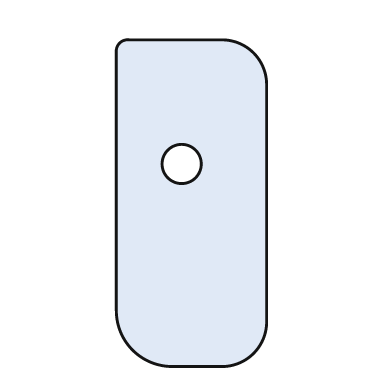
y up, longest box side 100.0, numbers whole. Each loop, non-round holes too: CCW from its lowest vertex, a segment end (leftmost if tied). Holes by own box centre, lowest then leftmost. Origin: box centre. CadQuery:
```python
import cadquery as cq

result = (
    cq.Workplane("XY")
    .moveTo(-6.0, -50.0)
    .lineTo(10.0, -50.0)
    .threePointArc((19.0, -46.0), (23.0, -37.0))
    .lineTo(23.0, 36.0)
    .threePointArc((19.0, 46.0), (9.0, 50.0))
    .lineTo(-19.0, 50.0)
    .threePointArc((-22.0, 49.0), (-23.0, 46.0))
    .lineTo(-23.0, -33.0)
    .threePointArc((-18.0, -45.0), (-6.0, -50.0))
    .close()
    .moveTo(-3.0, 12.0)
    .circle(6.0)
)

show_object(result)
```